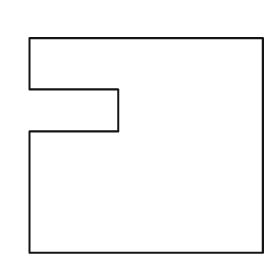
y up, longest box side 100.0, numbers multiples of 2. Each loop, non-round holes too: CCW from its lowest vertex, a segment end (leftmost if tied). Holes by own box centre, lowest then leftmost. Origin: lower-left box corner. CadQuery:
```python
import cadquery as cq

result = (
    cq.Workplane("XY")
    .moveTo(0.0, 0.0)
    .lineTo(100.0, 0.0)
    .lineTo(100.0, 92.0)
    .lineTo(0.0, 92.0)
    .lineTo(0.0, 70.0)
    .lineTo(38.0, 70.0)
    .lineTo(38.0, 52.0)
    .lineTo(0.0, 52.0)
    .close()
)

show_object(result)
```